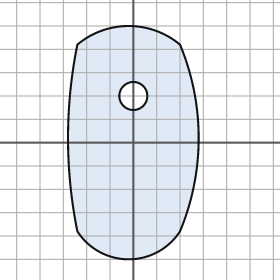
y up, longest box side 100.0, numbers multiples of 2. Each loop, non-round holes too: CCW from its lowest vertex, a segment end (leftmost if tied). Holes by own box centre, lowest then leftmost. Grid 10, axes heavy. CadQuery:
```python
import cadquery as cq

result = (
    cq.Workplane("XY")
    .moveTo(-24.0, -38.0)
    .threePointArc((-2.0, -50.0), (20.0, -38.0))
    .threePointArc((28.0, 2.0), (20.0, 42.0))
    .threePointArc((-2.0, 50.0), (-24.0, 42.0))
    .threePointArc((-28.0, 2.0), (-24.0, -38.0))
    .close()
    .moveTo(0.0, 20.0)
    .circle(6.0)
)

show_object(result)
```